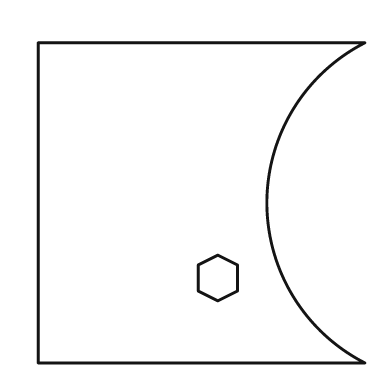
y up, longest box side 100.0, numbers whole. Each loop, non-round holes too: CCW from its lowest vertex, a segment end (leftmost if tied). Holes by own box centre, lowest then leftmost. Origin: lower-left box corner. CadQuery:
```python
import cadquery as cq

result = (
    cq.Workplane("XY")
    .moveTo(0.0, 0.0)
    .lineTo(100.0, 0.0)
    .threePointArc((70.0, 49.0), (100.0, 98.0))
    .lineTo(0.0, 98.0)
    .close()
    .moveTo(55.0, 19.0)
    .lineTo(61.0, 22.0)
    .lineTo(61.0, 30.0)
    .lineTo(55.0, 33.0)
    .lineTo(49.0, 30.0)
    .lineTo(49.0, 22.0)
    .close()
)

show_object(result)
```